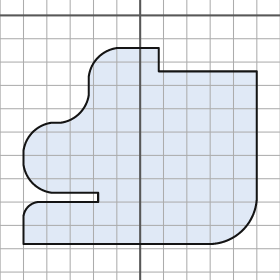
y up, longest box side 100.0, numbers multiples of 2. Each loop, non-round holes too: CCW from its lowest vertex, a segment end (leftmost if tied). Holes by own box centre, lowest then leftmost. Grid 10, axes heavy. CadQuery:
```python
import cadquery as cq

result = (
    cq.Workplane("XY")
    .moveTo(-50.0, -98.0)
    .lineTo(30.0, -98.0)
    .threePointArc((44.0, -92.0), (50.0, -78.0))
    .lineTo(50.0, -24.0)
    .lineTo(8.0, -24.0)
    .lineTo(8.0, -14.0)
    .lineTo(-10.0, -14.0)
    .threePointArc((-18.0, -18.0), (-22.0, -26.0))
    .lineTo(-22.0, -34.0)
    .threePointArc((-26.0, -42.0), (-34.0, -46.0))
    .lineTo(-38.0, -46.0)
    .threePointArc((-46.0, -50.0), (-50.0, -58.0))
    .lineTo(-50.0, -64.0)
    .threePointArc((-46.0, -72.0), (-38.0, -76.0))
    .lineTo(-18.0, -76.0)
    .lineTo(-18.0, -80.0)
    .lineTo(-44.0, -80.0)
    .threePointArc((-48.0, -82.0), (-50.0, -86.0))
    .close()
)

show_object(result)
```